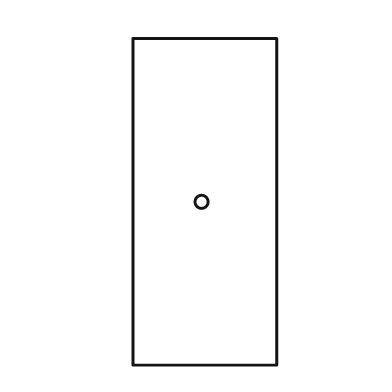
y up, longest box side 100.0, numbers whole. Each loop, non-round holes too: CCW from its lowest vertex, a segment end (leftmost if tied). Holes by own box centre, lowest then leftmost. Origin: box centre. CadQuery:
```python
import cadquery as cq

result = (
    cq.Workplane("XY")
    .moveTo(-22.0, -50.0)
    .lineTo(22.0, -50.0)
    .lineTo(22.0, 50.0)
    .lineTo(-22.0, 50.0)
    .close()
    .moveTo(-1.0, 0.0)
    .circle(2.0)
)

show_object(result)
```